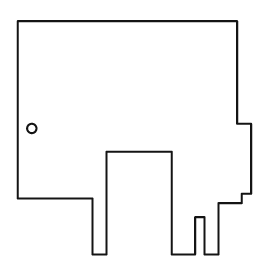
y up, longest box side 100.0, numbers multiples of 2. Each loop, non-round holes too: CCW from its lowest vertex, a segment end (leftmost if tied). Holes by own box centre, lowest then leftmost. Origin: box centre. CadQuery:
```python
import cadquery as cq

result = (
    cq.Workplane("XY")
    .moveTo(-18.0, -50.0)
    .lineTo(-12.0, -50.0)
    .lineTo(-12.0, -6.0)
    .lineTo(16.0, -6.0)
    .lineTo(16.0, -50.0)
    .lineTo(26.0, -50.0)
    .lineTo(26.0, -34.0)
    .lineTo(30.0, -34.0)
    .lineTo(30.0, -50.0)
    .lineTo(36.0, -50.0)
    .lineTo(36.0, -28.0)
    .lineTo(46.0, -28.0)
    .lineTo(46.0, -24.0)
    .lineTo(50.0, -24.0)
    .lineTo(50.0, 6.0)
    .lineTo(44.0, 6.0)
    .lineTo(44.0, 50.0)
    .lineTo(-50.0, 50.0)
    .lineTo(-50.0, -26.0)
    .lineTo(-18.0, -26.0)
    .close()
    .moveTo(-44.0, 4.0)
    .circle(2.0)
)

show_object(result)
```